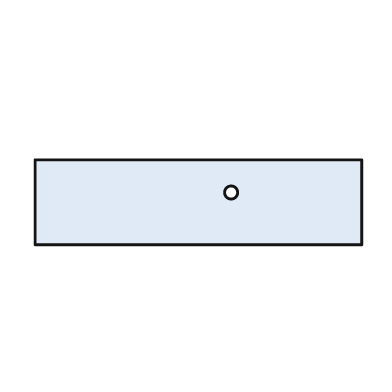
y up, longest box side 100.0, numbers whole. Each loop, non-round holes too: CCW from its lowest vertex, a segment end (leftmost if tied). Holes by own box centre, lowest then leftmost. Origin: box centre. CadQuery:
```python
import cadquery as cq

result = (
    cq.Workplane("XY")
    .moveTo(-50.0, -13.0)
    .lineTo(50.0, -13.0)
    .lineTo(50.0, 13.0)
    .lineTo(-50.0, 13.0)
    .close()
    .moveTo(10.0, 3.0)
    .circle(2.0)
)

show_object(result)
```